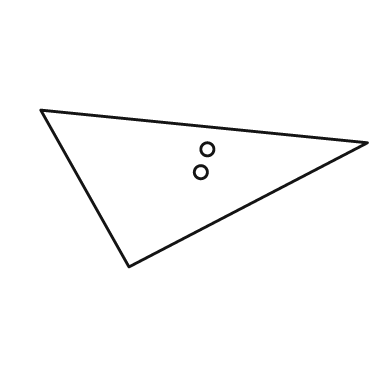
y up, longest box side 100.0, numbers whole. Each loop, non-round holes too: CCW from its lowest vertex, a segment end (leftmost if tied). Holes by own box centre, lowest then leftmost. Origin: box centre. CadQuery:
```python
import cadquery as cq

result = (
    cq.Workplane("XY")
    .moveTo(-23.0, -24.0)
    .lineTo(50.0, 14.0)
    .lineTo(-50.0, 24.0)
    .close()
    .moveTo(-1.0, 5.0)
    .circle(2.0)
    .moveTo(1.0, 12.0)
    .circle(2.0)
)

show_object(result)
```